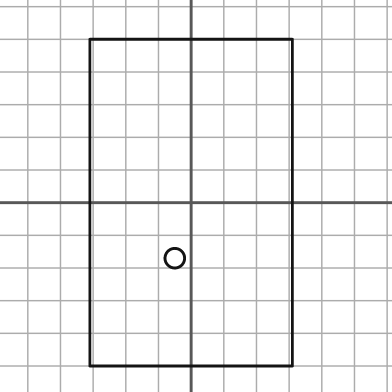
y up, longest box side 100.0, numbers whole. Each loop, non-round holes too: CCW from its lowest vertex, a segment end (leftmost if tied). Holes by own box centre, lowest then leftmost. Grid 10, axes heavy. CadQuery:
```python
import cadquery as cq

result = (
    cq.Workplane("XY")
    .moveTo(-31.0, -50.0)
    .lineTo(31.0, -50.0)
    .lineTo(31.0, 50.0)
    .lineTo(-31.0, 50.0)
    .close()
    .moveTo(-5.0, -17.0)
    .circle(3.0)
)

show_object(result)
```